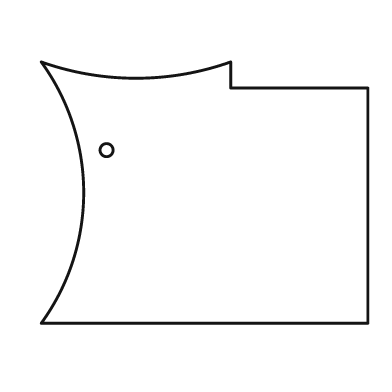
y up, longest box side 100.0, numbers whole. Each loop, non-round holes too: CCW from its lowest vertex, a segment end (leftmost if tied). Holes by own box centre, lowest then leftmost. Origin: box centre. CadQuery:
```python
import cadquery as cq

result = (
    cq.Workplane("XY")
    .moveTo(-50.0, -40.0)
    .lineTo(50.0, -40.0)
    .lineTo(50.0, 32.0)
    .lineTo(8.0, 32.0)
    .lineTo(8.0, 40.0)
    .threePointArc((-21.0, 35.0), (-50.0, 40.0))
    .threePointArc((-37.0, 0.0), (-50.0, -40.0))
    .close()
    .moveTo(-30.0, 13.0)
    .circle(2.0)
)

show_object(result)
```